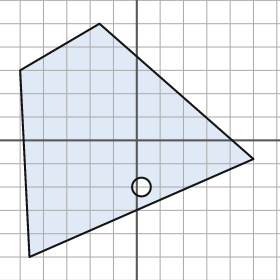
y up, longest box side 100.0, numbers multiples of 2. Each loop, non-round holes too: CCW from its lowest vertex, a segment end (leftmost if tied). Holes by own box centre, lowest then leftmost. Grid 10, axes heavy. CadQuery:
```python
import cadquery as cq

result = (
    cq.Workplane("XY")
    .moveTo(-46.0, -50.0)
    .lineTo(50.0, -8.0)
    .lineTo(-16.0, 50.0)
    .lineTo(-50.0, 30.0)
    .close()
    .moveTo(2.0, -20.0)
    .circle(4.0)
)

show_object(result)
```